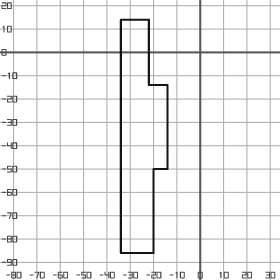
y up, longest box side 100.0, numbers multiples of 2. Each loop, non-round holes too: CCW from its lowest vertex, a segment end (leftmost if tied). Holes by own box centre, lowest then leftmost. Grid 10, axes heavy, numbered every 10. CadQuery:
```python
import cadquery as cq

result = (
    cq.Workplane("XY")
    .moveTo(-34.0, -86.0)
    .lineTo(-20.0, -86.0)
    .lineTo(-20.0, -50.0)
    .lineTo(-14.0, -50.0)
    .lineTo(-14.0, -14.0)
    .lineTo(-22.0, -14.0)
    .lineTo(-22.0, 14.0)
    .lineTo(-34.0, 14.0)
    .close()
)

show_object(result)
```